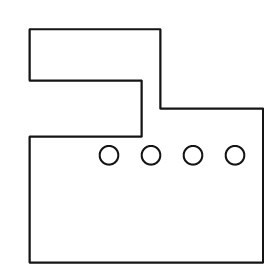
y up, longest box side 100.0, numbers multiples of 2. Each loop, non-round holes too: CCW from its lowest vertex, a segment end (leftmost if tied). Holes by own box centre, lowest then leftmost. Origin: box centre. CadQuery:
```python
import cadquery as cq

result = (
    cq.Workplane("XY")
    .moveTo(-50.0, -50.0)
    .lineTo(50.0, -50.0)
    .lineTo(50.0, 16.0)
    .lineTo(6.0, 16.0)
    .lineTo(6.0, 50.0)
    .lineTo(-50.0, 50.0)
    .lineTo(-50.0, 28.0)
    .lineTo(-2.0, 28.0)
    .lineTo(-2.0, 4.0)
    .lineTo(-50.0, 4.0)
    .close()
    .moveTo(-16.0, -4.0)
    .circle(4.0)
    .moveTo(2.0, -4.0)
    .circle(4.0)
    .moveTo(20.0, -4.0)
    .circle(4.0)
    .moveTo(38.0, -4.0)
    .circle(4.0)
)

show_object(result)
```